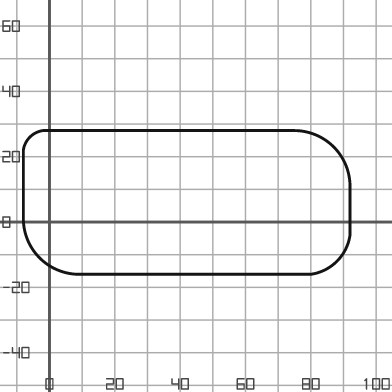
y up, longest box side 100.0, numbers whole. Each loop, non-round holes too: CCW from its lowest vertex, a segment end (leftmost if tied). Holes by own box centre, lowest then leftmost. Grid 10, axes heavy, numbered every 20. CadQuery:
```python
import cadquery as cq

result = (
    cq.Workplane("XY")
    .moveTo(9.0, -16.0)
    .lineTo(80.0, -16.0)
    .threePointArc((88.0, -12.0), (92.0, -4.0))
    .lineTo(92.0, 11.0)
    .threePointArc((87.0, 23.0), (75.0, 28.0))
    .lineTo(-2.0, 28.0)
    .threePointArc((-6.0, 26.0), (-8.0, 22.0))
    .lineTo(-8.0, 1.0)
    .threePointArc((-3.0, -11.0), (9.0, -16.0))
    .close()
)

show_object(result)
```